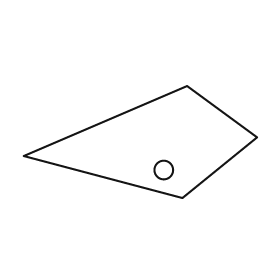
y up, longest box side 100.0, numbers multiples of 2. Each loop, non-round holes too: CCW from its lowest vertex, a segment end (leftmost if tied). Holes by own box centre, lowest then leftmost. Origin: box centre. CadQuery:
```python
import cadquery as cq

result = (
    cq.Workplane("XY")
    .moveTo(18.0, -24.0)
    .lineTo(50.0, 2.0)
    .lineTo(20.0, 24.0)
    .lineTo(-50.0, -6.0)
    .close()
    .moveTo(10.0, -12.0)
    .circle(4.0)
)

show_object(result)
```